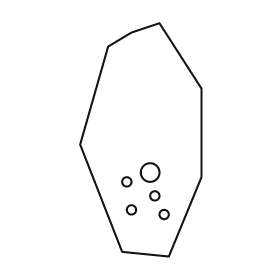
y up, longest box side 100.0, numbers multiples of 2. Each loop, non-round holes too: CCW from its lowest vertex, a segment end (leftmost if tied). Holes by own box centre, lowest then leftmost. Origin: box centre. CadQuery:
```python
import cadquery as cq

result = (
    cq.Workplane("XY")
    .moveTo(12.0, -50.0)
    .lineTo(26.0, -16.0)
    .lineTo(26.0, 22.0)
    .lineTo(8.0, 50.0)
    .lineTo(-4.0, 46.0)
    .lineTo(-14.0, 40.0)
    .lineTo(-26.0, -2.0)
    .lineTo(-8.0, -48.0)
    .close()
    .moveTo(10.0, -32.0)
    .circle(2.0)
    .moveTo(-4.0, -30.0)
    .circle(2.0)
    .moveTo(6.0, -24.0)
    .circle(2.0)
    .moveTo(-6.0, -18.0)
    .circle(2.0)
    .moveTo(4.0, -14.0)
    .circle(4.0)
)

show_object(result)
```